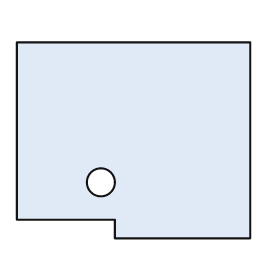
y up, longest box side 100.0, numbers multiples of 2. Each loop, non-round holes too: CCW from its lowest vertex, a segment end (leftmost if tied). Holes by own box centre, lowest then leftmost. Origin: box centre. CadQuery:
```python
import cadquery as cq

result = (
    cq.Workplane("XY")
    .moveTo(-8.0, -42.0)
    .lineTo(50.0, -42.0)
    .lineTo(50.0, 42.0)
    .lineTo(-50.0, 42.0)
    .lineTo(-50.0, -34.0)
    .lineTo(-8.0, -34.0)
    .close()
    .moveTo(-14.0, -18.0)
    .circle(6.0)
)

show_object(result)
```